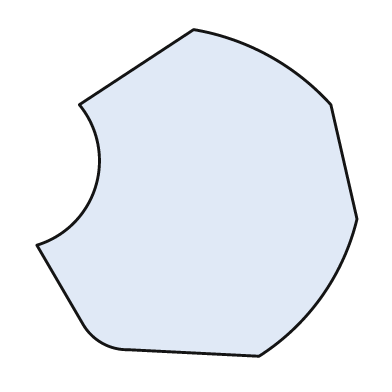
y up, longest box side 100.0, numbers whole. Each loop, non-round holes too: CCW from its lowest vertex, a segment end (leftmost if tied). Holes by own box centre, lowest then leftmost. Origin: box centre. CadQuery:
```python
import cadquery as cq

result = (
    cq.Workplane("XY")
    .moveTo(19.0, -50.0)
    .threePointArc((38.0, -32.0), (49.0, -8.0))
    .lineTo(41.0, 27.0)
    .threePointArc((22.0, 42.0), (-1.0, 50.0))
    .lineTo(-36.0, 27.0)
    .threePointArc((-31.0, 2.0), (-49.0, -16.0))
    .lineTo(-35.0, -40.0)
    .threePointArc((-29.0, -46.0), (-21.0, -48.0))
    .close()
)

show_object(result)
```